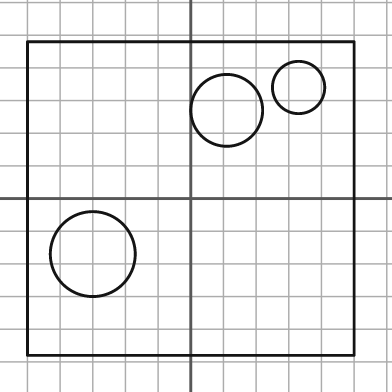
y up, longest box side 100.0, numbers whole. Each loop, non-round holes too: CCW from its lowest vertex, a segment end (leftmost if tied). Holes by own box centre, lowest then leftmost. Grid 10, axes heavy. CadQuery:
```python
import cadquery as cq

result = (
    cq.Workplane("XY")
    .moveTo(-50.0, -48.0)
    .lineTo(50.0, -48.0)
    .lineTo(50.0, 48.0)
    .lineTo(-50.0, 48.0)
    .close()
    .moveTo(-30.0, -17.0)
    .circle(13.0)
    .moveTo(11.0, 27.0)
    .circle(11.0)
    .moveTo(33.0, 34.0)
    .circle(8.0)
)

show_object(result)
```